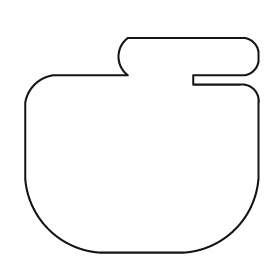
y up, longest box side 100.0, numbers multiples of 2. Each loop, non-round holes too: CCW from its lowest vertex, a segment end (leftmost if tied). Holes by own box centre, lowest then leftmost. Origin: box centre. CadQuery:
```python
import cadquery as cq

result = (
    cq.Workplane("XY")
    .moveTo(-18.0, -46.0)
    .lineTo(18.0, -46.0)
    .threePointArc((40.0, -36.0), (50.0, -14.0))
    .lineTo(50.0, 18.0)
    .threePointArc((48.0, 24.0), (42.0, 26.0))
    .lineTo(22.0, 26.0)
    .lineTo(22.0, 30.0)
    .lineTo(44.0, 30.0)
    .threePointArc((48.0, 32.0), (50.0, 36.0))
    .lineTo(50.0, 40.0)
    .threePointArc((48.0, 44.0), (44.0, 46.0))
    .lineTo(-6.0, 46.0)
    .threePointArc((-10.0, 38.0), (-6.0, 30.0))
    .lineTo(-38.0, 30.0)
    .threePointArc((-46.0, 26.0), (-50.0, 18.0))
    .lineTo(-50.0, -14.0)
    .threePointArc((-40.0, -36.0), (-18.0, -46.0))
    .close()
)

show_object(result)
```